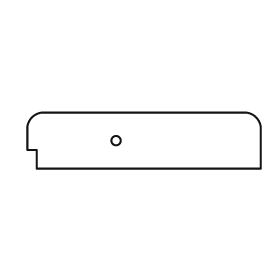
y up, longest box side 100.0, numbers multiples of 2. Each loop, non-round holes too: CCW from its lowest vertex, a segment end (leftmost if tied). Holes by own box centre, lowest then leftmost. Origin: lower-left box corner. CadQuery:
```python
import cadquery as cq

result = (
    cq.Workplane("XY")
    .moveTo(4.0, 0.0)
    .lineTo(100.0, 0.0)
    .lineTo(100.0, 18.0)
    .threePointArc((98.0, 22.0), (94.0, 24.0))
    .lineTo(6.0, 24.0)
    .threePointArc((2.0, 22.0), (0.0, 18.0))
    .lineTo(0.0, 8.0)
    .lineTo(4.0, 8.0)
    .close()
    .moveTo(38.0, 12.0)
    .circle(2.0)
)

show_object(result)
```